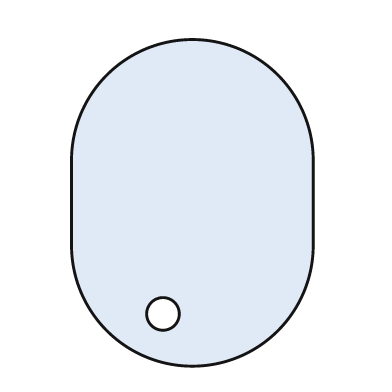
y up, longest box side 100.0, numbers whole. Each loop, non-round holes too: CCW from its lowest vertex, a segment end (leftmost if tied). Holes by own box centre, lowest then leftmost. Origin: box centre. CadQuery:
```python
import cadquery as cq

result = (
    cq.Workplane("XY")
    .moveTo(-37.0, -13.0)
    .threePointArc((0.0, -50.0), (37.0, -13.0))
    .lineTo(37.0, 13.0)
    .threePointArc((0.0, 50.0), (-37.0, 13.0))
    .close()
    .moveTo(-9.0, -34.0)
    .circle(5.0)
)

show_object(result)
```